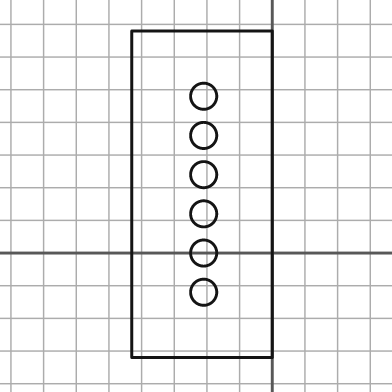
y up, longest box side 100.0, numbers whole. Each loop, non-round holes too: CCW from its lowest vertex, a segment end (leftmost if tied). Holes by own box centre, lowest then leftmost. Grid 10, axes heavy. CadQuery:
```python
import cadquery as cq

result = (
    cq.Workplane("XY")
    .moveTo(-43.0, -32.0)
    .lineTo(0.0, -32.0)
    .lineTo(0.0, 68.0)
    .lineTo(-43.0, 68.0)
    .close()
    .moveTo(-21.0, -12.0)
    .circle(4.0)
    .moveTo(-21.0, 0.0)
    .circle(4.0)
    .moveTo(-21.0, 12.0)
    .circle(4.0)
    .moveTo(-21.0, 24.0)
    .circle(4.0)
    .moveTo(-21.0, 36.0)
    .circle(4.0)
    .moveTo(-21.0, 48.0)
    .circle(4.0)
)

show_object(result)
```